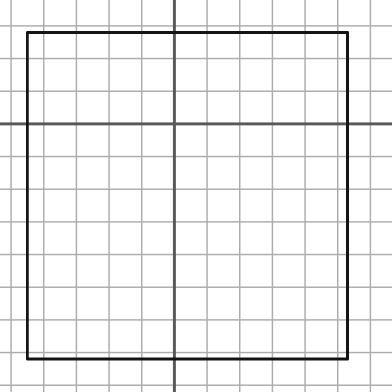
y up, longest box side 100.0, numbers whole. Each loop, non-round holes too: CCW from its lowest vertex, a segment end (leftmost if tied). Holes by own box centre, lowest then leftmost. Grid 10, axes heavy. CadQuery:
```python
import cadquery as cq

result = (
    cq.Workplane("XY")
    .moveTo(-45.0, -72.0)
    .lineTo(53.0, -72.0)
    .lineTo(53.0, 28.0)
    .lineTo(-45.0, 28.0)
    .close()
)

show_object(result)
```